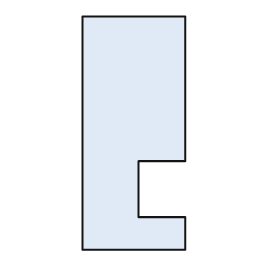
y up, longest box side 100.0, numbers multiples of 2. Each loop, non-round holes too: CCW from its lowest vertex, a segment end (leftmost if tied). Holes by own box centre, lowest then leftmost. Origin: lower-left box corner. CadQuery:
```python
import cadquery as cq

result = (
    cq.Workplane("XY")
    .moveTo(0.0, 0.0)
    .lineTo(44.0, 0.0)
    .lineTo(44.0, 14.0)
    .lineTo(24.0, 14.0)
    .lineTo(24.0, 38.0)
    .lineTo(44.0, 38.0)
    .lineTo(44.0, 100.0)
    .lineTo(0.0, 100.0)
    .close()
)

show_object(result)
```